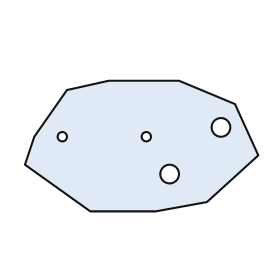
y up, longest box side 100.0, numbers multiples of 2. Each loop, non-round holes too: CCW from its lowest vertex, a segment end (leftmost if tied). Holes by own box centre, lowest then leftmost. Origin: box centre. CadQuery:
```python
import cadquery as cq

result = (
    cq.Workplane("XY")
    .moveTo(-22.0, -28.0)
    .lineTo(6.0, -28.0)
    .lineTo(28.0, -24.0)
    .lineTo(50.0, -4.0)
    .lineTo(40.0, 18.0)
    .lineTo(16.0, 28.0)
    .lineTo(-14.0, 28.0)
    .lineTo(-32.0, 24.0)
    .lineTo(-46.0, 4.0)
    .lineTo(-50.0, -8.0)
    .close()
    .moveTo(12.0, -12.0)
    .circle(4.0)
    .moveTo(-34.0, 4.0)
    .circle(2.0)
    .moveTo(2.0, 4.0)
    .circle(2.0)
    .moveTo(34.0, 8.0)
    .circle(4.0)
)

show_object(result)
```